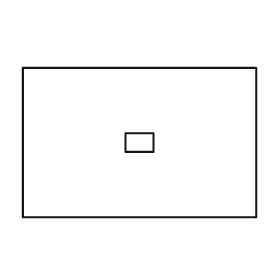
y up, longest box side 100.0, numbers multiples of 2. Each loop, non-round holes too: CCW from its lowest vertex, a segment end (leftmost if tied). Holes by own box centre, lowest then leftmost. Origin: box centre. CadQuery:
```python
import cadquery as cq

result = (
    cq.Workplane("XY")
    .moveTo(-50.0, -32.0)
    .lineTo(50.0, -32.0)
    .lineTo(50.0, 32.0)
    .lineTo(-50.0, 32.0)
    .close()
    .moveTo(-6.0, -4.0)
    .lineTo(6.0, -4.0)
    .lineTo(6.0, 4.0)
    .lineTo(-6.0, 4.0)
    .close()
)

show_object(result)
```